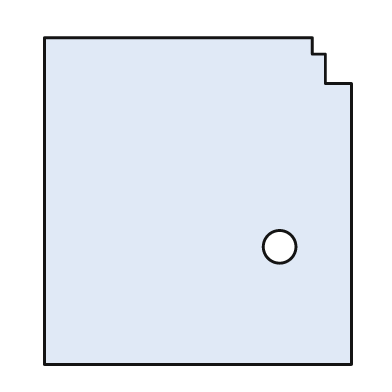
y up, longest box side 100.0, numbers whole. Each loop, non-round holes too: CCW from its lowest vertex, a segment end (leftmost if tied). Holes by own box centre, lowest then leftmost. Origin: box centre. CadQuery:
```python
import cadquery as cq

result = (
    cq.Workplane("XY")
    .moveTo(-47.0, -50.0)
    .lineTo(47.0, -50.0)
    .lineTo(47.0, 36.0)
    .lineTo(39.0, 36.0)
    .lineTo(39.0, 45.0)
    .lineTo(35.0, 45.0)
    .lineTo(35.0, 50.0)
    .lineTo(-47.0, 50.0)
    .close()
    .moveTo(25.0, -14.0)
    .circle(5.0)
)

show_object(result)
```